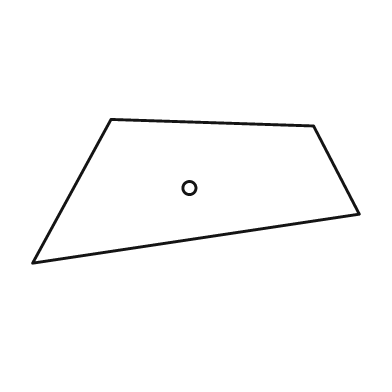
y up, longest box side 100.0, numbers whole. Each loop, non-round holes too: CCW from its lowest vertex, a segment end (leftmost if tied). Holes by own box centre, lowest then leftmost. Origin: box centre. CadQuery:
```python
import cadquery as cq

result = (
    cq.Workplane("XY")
    .moveTo(-50.0, -22.0)
    .lineTo(50.0, -7.0)
    .lineTo(36.0, 20.0)
    .lineTo(-26.0, 22.0)
    .close()
    .moveTo(-2.0, 1.0)
    .circle(2.0)
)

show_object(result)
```